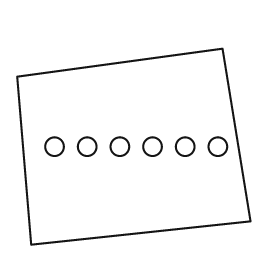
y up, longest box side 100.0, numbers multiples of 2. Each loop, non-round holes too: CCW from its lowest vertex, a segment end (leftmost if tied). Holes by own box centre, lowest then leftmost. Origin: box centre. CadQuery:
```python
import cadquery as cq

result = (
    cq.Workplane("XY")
    .moveTo(-44.0, -42.0)
    .lineTo(50.0, -32.0)
    .lineTo(38.0, 42.0)
    .lineTo(-50.0, 30.0)
    .close()
    .moveTo(-34.0, 0.0)
    .circle(4.0)
    .moveTo(-20.0, 0.0)
    .circle(4.0)
    .moveTo(-6.0, 0.0)
    .circle(4.0)
    .moveTo(8.0, 0.0)
    .circle(4.0)
    .moveTo(22.0, 0.0)
    .circle(4.0)
    .moveTo(36.0, 0.0)
    .circle(4.0)
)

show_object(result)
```